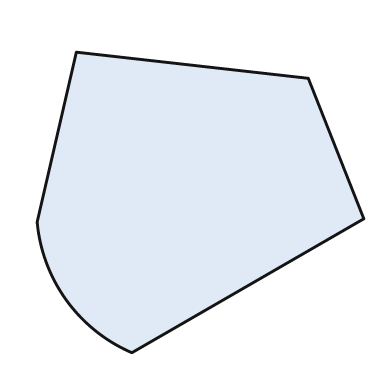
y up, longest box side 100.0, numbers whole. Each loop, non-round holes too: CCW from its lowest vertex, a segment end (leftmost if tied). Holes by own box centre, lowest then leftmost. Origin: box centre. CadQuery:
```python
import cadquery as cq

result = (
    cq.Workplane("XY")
    .moveTo(-21.0, -46.0)
    .lineTo(50.0, -5.0)
    .lineTo(33.0, 38.0)
    .lineTo(-38.0, 46.0)
    .lineTo(-50.0, -6.0)
    .threePointArc((-41.0, -30.0), (-21.0, -46.0))
    .close()
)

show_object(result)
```